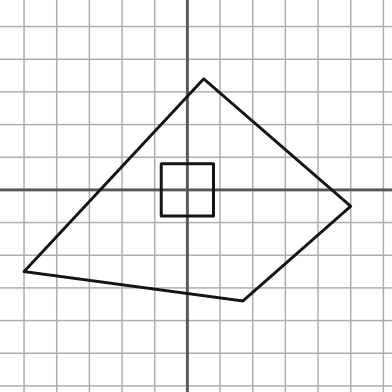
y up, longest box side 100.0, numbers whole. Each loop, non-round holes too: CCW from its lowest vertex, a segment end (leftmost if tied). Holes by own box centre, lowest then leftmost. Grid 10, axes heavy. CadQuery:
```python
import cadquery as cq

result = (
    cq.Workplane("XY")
    .moveTo(17.0, -34.0)
    .lineTo(50.0, -5.0)
    .lineTo(5.0, 34.0)
    .lineTo(-50.0, -25.0)
    .close()
    .moveTo(-8.0, -8.0)
    .lineTo(8.0, -8.0)
    .lineTo(8.0, 8.0)
    .lineTo(-8.0, 8.0)
    .close()
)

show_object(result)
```